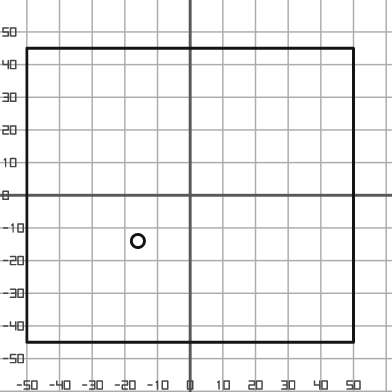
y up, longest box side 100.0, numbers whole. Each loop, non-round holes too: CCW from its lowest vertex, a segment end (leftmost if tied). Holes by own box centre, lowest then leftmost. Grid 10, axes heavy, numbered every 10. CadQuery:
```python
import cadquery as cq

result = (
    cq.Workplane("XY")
    .moveTo(-50.0, -45.0)
    .lineTo(50.0, -45.0)
    .lineTo(50.0, 45.0)
    .lineTo(-50.0, 45.0)
    .close()
    .moveTo(-16.0, -14.0)
    .circle(2.0)
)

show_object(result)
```